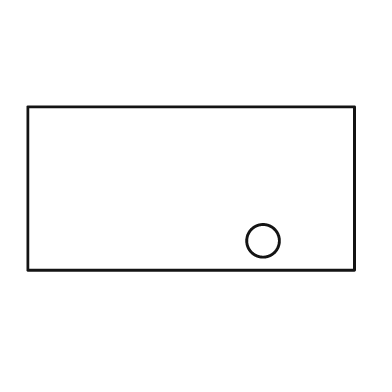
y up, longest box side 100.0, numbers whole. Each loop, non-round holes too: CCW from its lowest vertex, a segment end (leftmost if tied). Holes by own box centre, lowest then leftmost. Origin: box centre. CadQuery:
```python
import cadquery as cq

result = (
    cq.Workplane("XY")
    .moveTo(-50.0, -25.0)
    .lineTo(50.0, -25.0)
    .lineTo(50.0, 25.0)
    .lineTo(-50.0, 25.0)
    .close()
    .moveTo(22.0, -16.0)
    .circle(5.0)
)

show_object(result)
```